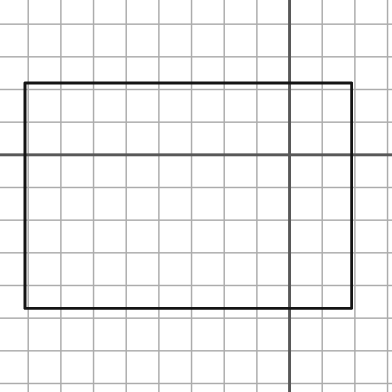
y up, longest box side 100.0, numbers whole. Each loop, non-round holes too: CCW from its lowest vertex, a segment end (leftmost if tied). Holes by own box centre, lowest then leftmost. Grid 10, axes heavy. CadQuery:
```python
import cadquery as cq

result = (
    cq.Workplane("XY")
    .moveTo(-81.0, -47.0)
    .lineTo(19.0, -47.0)
    .lineTo(19.0, 22.0)
    .lineTo(-81.0, 22.0)
    .close()
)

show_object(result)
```